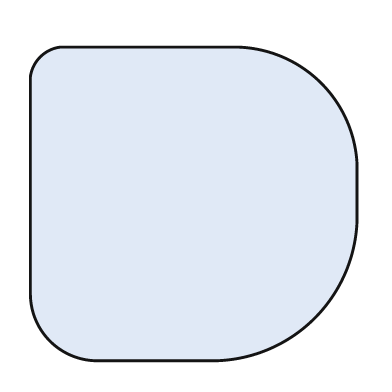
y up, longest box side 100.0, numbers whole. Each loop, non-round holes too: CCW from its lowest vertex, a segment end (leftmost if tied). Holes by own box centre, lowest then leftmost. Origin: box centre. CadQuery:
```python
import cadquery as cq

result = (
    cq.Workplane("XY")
    .moveTo(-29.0, -48.0)
    .lineTo(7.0, -48.0)
    .threePointArc((37.0, -35.0), (50.0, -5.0))
    .lineTo(50.0, 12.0)
    .threePointArc((39.0, 37.0), (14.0, 48.0))
    .lineTo(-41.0, 48.0)
    .threePointArc((-47.0, 45.0), (-50.0, 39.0))
    .lineTo(-50.0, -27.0)
    .threePointArc((-44.0, -42.0), (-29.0, -48.0))
    .close()
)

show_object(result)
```